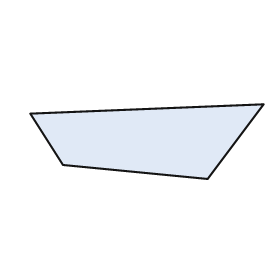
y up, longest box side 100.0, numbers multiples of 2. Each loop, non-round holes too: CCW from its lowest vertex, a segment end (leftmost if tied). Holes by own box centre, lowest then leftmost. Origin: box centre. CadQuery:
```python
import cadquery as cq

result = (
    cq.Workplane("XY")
    .moveTo(26.0, -16.0)
    .lineTo(50.0, 16.0)
    .lineTo(-50.0, 12.0)
    .lineTo(-36.0, -10.0)
    .close()
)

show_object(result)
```